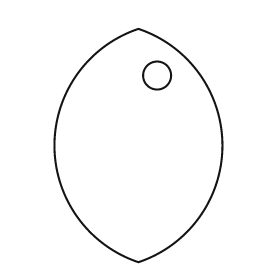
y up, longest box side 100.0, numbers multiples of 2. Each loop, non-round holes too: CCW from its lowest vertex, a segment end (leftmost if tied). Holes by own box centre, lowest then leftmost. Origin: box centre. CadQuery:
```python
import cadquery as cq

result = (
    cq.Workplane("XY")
    .moveTo(0.0, -50.0)
    .threePointArc((36.0, 0.0), (0.0, 50.0))
    .threePointArc((-36.0, 0.0), (0.0, -50.0))
    .close()
    .moveTo(8.0, 30.0)
    .circle(6.0)
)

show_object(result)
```